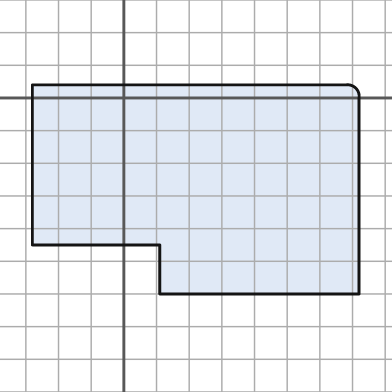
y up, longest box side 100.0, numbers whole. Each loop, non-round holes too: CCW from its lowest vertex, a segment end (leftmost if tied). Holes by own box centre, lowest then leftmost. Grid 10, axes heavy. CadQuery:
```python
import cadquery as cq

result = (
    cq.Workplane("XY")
    .moveTo(11.0, -60.0)
    .lineTo(72.0, -60.0)
    .lineTo(72.0, 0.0)
    .threePointArc((71.0, 3.0), (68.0, 4.0))
    .lineTo(-28.0, 4.0)
    .lineTo(-28.0, -45.0)
    .lineTo(11.0, -45.0)
    .close()
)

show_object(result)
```